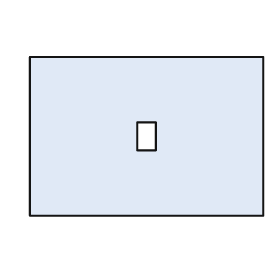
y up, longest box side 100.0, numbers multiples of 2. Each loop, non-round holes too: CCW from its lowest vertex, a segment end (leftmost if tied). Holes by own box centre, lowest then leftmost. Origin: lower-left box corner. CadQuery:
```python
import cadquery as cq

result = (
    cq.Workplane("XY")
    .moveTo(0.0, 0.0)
    .lineTo(100.0, 0.0)
    .lineTo(100.0, 68.0)
    .lineTo(0.0, 68.0)
    .close()
    .moveTo(46.0, 28.0)
    .lineTo(54.0, 28.0)
    .lineTo(54.0, 40.0)
    .lineTo(46.0, 40.0)
    .close()
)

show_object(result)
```